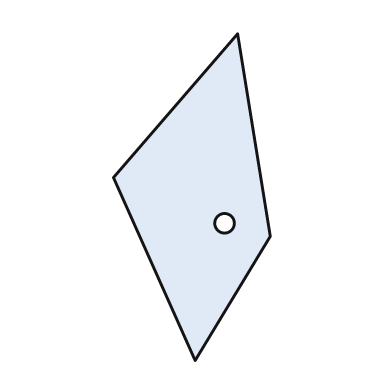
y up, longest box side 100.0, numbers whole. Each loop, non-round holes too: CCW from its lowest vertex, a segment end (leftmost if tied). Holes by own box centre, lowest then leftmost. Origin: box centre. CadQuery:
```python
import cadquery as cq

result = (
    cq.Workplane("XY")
    .moveTo(1.0, -50.0)
    .lineTo(24.0, -12.0)
    .lineTo(14.0, 50.0)
    .lineTo(-24.0, 6.0)
    .close()
    .moveTo(10.0, -8.0)
    .circle(3.0)
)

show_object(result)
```